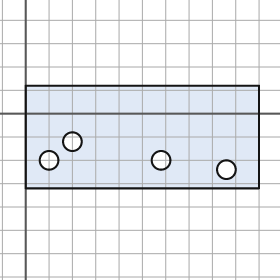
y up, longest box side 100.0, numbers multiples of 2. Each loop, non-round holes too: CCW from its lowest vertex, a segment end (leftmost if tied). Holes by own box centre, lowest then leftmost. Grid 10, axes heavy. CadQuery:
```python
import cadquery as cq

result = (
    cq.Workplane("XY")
    .moveTo(0.0, -32.0)
    .lineTo(100.0, -32.0)
    .lineTo(100.0, 12.0)
    .lineTo(0.0, 12.0)
    .close()
    .moveTo(86.0, -24.0)
    .circle(4.0)
    .moveTo(10.0, -20.0)
    .circle(4.0)
    .moveTo(58.0, -20.0)
    .circle(4.0)
    .moveTo(20.0, -12.0)
    .circle(4.0)
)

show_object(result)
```